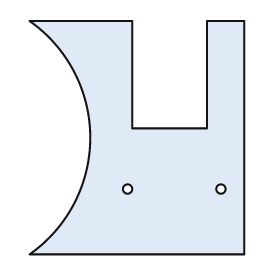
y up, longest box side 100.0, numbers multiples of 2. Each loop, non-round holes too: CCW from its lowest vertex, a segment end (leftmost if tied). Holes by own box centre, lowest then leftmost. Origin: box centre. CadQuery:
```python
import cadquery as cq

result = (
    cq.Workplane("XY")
    .moveTo(-46.0, -50.0)
    .lineTo(46.0, -50.0)
    .lineTo(46.0, 50.0)
    .lineTo(30.0, 50.0)
    .lineTo(30.0, 4.0)
    .lineTo(-2.0, 4.0)
    .lineTo(-2.0, 50.0)
    .lineTo(-46.0, 50.0)
    .threePointArc((-20.0, 0.0), (-46.0, -50.0))
    .close()
    .moveTo(-4.0, -22.0)
    .circle(2.0)
    .moveTo(36.0, -22.0)
    .circle(2.0)
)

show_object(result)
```